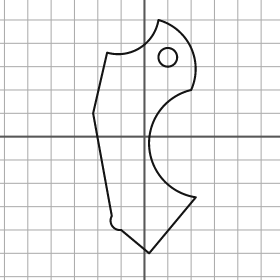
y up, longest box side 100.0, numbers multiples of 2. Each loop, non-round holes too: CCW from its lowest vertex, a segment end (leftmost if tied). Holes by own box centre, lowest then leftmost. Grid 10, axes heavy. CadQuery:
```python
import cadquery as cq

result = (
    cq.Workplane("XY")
    .moveTo(2.0, -50.0)
    .lineTo(22.0, -26.0)
    .threePointArc((2.0, -4.0), (20.0, 20.0))
    .threePointArc((20.0, 38.0), (6.0, 50.0))
    .threePointArc((-2.0, 38.0), (-16.0, 36.0))
    .lineTo(-22.0, 10.0)
    .lineTo(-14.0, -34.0)
    .threePointArc((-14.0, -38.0), (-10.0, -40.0))
    .close()
    .moveTo(10.0, 34.0)
    .circle(4.0)
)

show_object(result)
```